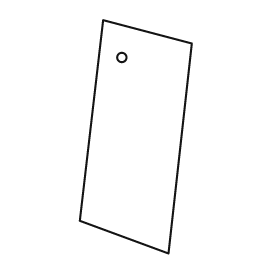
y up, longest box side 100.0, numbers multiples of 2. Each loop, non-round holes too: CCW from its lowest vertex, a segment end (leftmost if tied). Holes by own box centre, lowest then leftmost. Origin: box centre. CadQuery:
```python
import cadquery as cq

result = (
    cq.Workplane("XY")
    .moveTo(14.0, -50.0)
    .lineTo(24.0, 40.0)
    .lineTo(-14.0, 50.0)
    .lineTo(-24.0, -36.0)
    .close()
    .moveTo(-6.0, 34.0)
    .circle(2.0)
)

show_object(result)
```